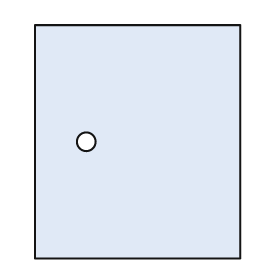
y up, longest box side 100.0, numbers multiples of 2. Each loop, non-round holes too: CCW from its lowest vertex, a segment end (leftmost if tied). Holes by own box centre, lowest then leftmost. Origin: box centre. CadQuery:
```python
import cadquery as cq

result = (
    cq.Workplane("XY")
    .moveTo(-44.0, -50.0)
    .lineTo(44.0, -50.0)
    .lineTo(44.0, 50.0)
    .lineTo(-44.0, 50.0)
    .close()
    .moveTo(-22.0, 0.0)
    .circle(4.0)
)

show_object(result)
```